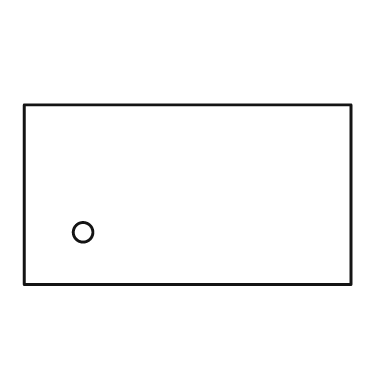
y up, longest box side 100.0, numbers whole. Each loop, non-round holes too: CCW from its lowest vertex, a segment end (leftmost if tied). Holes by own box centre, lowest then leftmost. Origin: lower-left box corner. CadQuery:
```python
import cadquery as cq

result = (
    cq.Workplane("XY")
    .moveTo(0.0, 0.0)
    .lineTo(100.0, 0.0)
    .lineTo(100.0, 55.0)
    .lineTo(0.0, 55.0)
    .close()
    .moveTo(18.0, 16.0)
    .circle(3.0)
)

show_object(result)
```